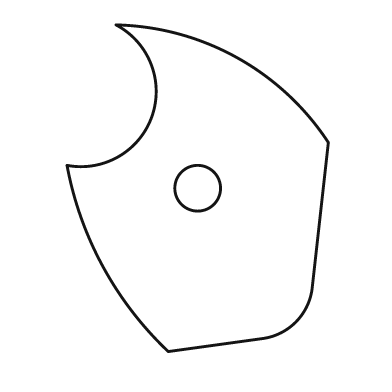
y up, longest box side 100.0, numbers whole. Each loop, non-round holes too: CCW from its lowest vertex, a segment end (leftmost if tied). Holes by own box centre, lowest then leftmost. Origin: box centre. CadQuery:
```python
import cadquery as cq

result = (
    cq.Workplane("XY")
    .moveTo(-9.0, -50.0)
    .lineTo(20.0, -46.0)
    .threePointArc((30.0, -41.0), (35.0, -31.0))
    .lineTo(40.0, 14.0)
    .threePointArc((12.0, 40.0), (-25.0, 50.0))
    .threePointArc((-14.0, 22.0), (-40.0, 7.0))
    .threePointArc((-29.0, -24.0), (-9.0, -50.0))
    .close()
    .moveTo(0.0, 0.0)
    .circle(7.0)
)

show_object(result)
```